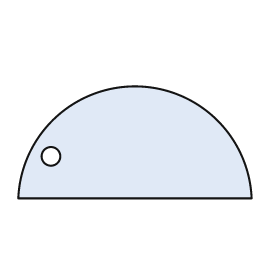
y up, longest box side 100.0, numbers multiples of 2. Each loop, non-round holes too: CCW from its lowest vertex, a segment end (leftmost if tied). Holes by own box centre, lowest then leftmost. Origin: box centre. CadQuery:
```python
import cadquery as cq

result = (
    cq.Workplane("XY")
    .moveTo(-50.0, -24.0)
    .lineTo(50.0, -24.0)
    .threePointArc((0.0, 24.0), (-50.0, -24.0))
    .close()
    .moveTo(-36.0, -6.0)
    .circle(4.0)
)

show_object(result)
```